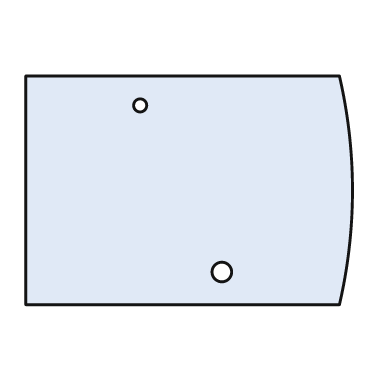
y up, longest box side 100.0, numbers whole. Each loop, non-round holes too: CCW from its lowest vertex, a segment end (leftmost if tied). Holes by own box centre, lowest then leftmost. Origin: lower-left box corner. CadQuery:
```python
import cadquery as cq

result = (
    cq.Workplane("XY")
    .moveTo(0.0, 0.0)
    .lineTo(96.0, 0.0)
    .threePointArc((100.0, 35.0), (96.0, 70.0))
    .lineTo(0.0, 70.0)
    .close()
    .moveTo(60.0, 10.0)
    .circle(3.0)
    .moveTo(35.0, 61.0)
    .circle(2.0)
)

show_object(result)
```